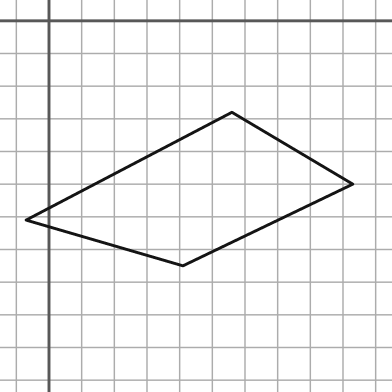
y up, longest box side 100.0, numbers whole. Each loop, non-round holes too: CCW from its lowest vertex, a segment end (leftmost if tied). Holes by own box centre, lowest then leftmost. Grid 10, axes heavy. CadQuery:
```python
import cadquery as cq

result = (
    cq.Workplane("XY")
    .moveTo(41.0, -75.0)
    .lineTo(93.0, -50.0)
    .lineTo(56.0, -28.0)
    .lineTo(-7.0, -61.0)
    .close()
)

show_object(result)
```